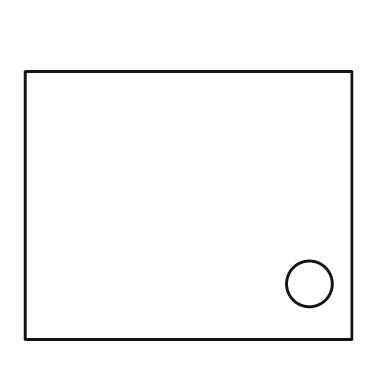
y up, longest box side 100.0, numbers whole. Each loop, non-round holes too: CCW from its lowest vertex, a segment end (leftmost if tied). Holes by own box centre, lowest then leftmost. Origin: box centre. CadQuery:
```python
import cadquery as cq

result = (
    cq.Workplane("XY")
    .moveTo(-50.0, -41.0)
    .lineTo(50.0, -41.0)
    .lineTo(50.0, 41.0)
    .lineTo(-50.0, 41.0)
    .close()
    .moveTo(37.0, -24.0)
    .circle(7.0)
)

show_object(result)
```